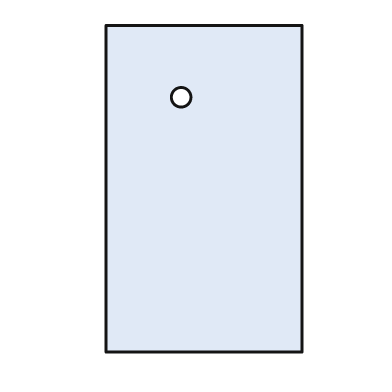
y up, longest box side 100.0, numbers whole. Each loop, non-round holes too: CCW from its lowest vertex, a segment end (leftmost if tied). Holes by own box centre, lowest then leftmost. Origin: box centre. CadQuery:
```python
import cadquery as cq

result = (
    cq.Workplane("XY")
    .moveTo(-30.0, -50.0)
    .lineTo(30.0, -50.0)
    .lineTo(30.0, 50.0)
    .lineTo(-30.0, 50.0)
    .close()
    .moveTo(-7.0, 28.0)
    .circle(3.0)
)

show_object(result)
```